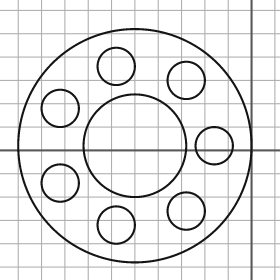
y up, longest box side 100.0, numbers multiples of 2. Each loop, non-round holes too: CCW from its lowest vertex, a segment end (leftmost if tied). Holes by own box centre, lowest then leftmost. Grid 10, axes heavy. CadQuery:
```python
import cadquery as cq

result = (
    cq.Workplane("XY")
    .moveTo(-50.0, 2.0)
    .circle(50.0)
    .moveTo(-58.0, -32.0)
    .circle(8.0)
    .moveTo(-28.0, -26.0)
    .circle(8.0)
    .moveTo(-82.0, -14.0)
    .circle(8.0)
    .moveTo(-50.0, 2.0)
    .circle(22.0)
    .moveTo(-16.0, 2.0)
    .circle(8.0)
    .moveTo(-82.0, 18.0)
    .circle(8.0)
    .moveTo(-28.0, 30.0)
    .circle(8.0)
    .moveTo(-58.0, 36.0)
    .circle(8.0)
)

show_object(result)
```